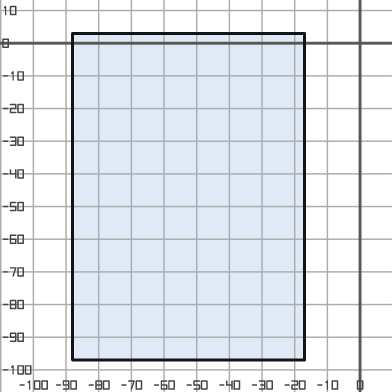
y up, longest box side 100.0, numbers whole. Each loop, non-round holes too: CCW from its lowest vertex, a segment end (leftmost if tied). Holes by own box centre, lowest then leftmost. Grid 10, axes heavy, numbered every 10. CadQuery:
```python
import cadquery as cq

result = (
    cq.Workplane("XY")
    .moveTo(-88.0, -97.0)
    .lineTo(-17.0, -97.0)
    .lineTo(-17.0, 3.0)
    .lineTo(-88.0, 3.0)
    .close()
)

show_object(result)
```